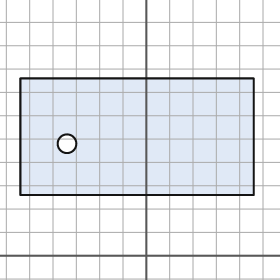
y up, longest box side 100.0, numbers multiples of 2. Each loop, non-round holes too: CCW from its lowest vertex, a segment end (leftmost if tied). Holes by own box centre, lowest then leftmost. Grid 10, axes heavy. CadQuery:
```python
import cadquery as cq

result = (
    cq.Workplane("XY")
    .moveTo(-54.0, 26.0)
    .lineTo(46.0, 26.0)
    .lineTo(46.0, 76.0)
    .lineTo(-54.0, 76.0)
    .close()
    .moveTo(-34.0, 48.0)
    .circle(4.0)
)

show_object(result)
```